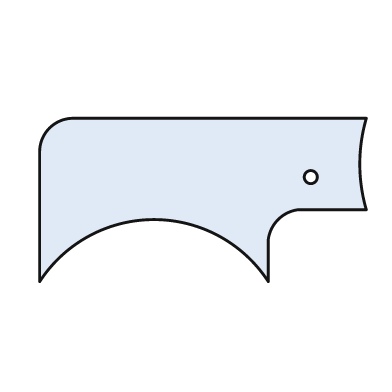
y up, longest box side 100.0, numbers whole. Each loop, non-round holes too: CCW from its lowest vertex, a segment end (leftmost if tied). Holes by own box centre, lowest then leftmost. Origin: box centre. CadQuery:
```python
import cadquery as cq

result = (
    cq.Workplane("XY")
    .moveTo(-50.0, -25.0)
    .threePointArc((-15.0, -6.0), (20.0, -25.0))
    .lineTo(20.0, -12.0)
    .threePointArc((23.0, -6.0), (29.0, -3.0))
    .lineTo(50.0, -3.0)
    .threePointArc((48.0, 11.0), (50.0, 25.0))
    .lineTo(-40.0, 25.0)
    .threePointArc((-47.0, 22.0), (-50.0, 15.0))
    .close()
    .moveTo(33.0, 7.0)
    .circle(2.0)
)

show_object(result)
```